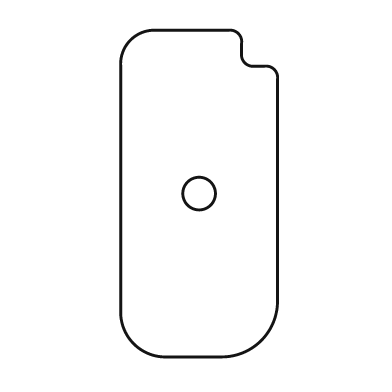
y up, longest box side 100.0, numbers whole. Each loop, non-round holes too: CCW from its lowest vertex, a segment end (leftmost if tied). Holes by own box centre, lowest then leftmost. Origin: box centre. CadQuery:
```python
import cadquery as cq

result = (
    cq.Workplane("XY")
    .moveTo(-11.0, -50.0)
    .lineTo(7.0, -50.0)
    .threePointArc((19.0, -45.0), (24.0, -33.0))
    .lineTo(24.0, 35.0)
    .threePointArc((23.0, 38.0), (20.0, 39.0))
    .lineTo(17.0, 39.0)
    .threePointArc((14.0, 40.0), (13.0, 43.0))
    .lineTo(13.0, 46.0)
    .threePointArc((12.0, 49.0), (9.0, 50.0))
    .lineTo(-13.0, 50.0)
    .threePointArc((-21.0, 47.0), (-24.0, 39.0))
    .lineTo(-24.0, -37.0)
    .threePointArc((-20.0, -46.0), (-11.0, -50.0))
    .close()
    .moveTo(0.0, 0.0)
    .circle(5.0)
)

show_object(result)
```